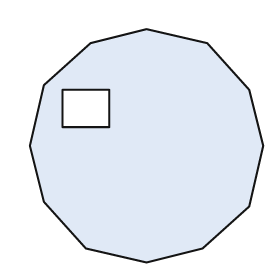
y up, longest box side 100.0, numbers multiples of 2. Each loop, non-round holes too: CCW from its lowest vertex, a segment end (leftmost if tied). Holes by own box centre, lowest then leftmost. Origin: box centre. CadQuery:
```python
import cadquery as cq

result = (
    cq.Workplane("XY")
    .moveTo(0.0, -50.0)
    .lineTo(24.0, -44.0)
    .lineTo(44.0, -26.0)
    .lineTo(50.0, 0.0)
    .lineTo(44.0, 24.0)
    .lineTo(26.0, 44.0)
    .lineTo(0.0, 50.0)
    .lineTo(-24.0, 44.0)
    .lineTo(-44.0, 26.0)
    .lineTo(-50.0, 0.0)
    .lineTo(-44.0, -24.0)
    .lineTo(-26.0, -44.0)
    .close()
    .moveTo(-36.0, 8.0)
    .lineTo(-16.0, 8.0)
    .lineTo(-16.0, 24.0)
    .lineTo(-36.0, 24.0)
    .close()
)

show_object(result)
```